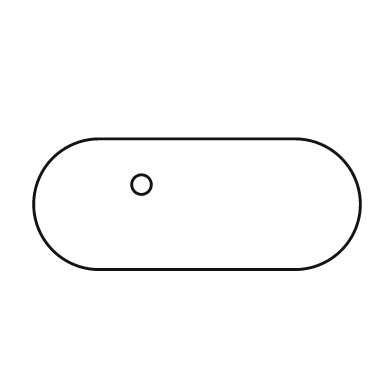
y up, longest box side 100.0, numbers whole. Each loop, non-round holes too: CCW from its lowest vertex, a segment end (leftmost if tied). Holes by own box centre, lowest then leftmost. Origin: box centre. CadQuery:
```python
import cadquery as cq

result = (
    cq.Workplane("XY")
    .moveTo(-30.0, -20.0)
    .lineTo(30.0, -20.0)
    .threePointArc((50.0, 0.0), (30.0, 20.0))
    .lineTo(-30.0, 20.0)
    .threePointArc((-50.0, 0.0), (-30.0, -20.0))
    .close()
    .moveTo(-17.0, 6.0)
    .circle(3.0)
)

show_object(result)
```